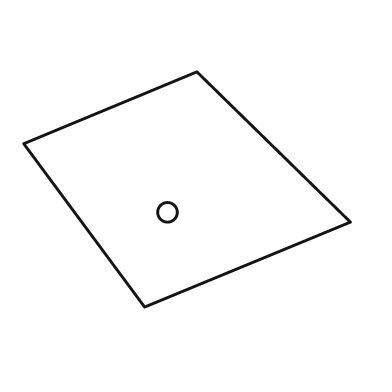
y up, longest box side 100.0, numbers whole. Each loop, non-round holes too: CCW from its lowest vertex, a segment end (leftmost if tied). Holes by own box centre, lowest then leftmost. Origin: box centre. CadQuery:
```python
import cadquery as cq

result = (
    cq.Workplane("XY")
    .moveTo(-13.0, -36.0)
    .lineTo(50.0, -10.0)
    .lineTo(3.0, 36.0)
    .lineTo(-50.0, 14.0)
    .close()
    .moveTo(-6.0, -7.0)
    .circle(3.0)
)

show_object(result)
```